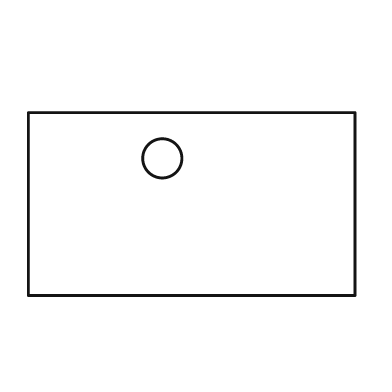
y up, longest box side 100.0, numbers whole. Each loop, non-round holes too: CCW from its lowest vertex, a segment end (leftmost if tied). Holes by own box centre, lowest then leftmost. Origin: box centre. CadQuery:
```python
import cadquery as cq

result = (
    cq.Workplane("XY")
    .moveTo(-50.0, -28.0)
    .lineTo(50.0, -28.0)
    .lineTo(50.0, 28.0)
    .lineTo(-50.0, 28.0)
    .close()
    .moveTo(-9.0, 14.0)
    .circle(6.0)
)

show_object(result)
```